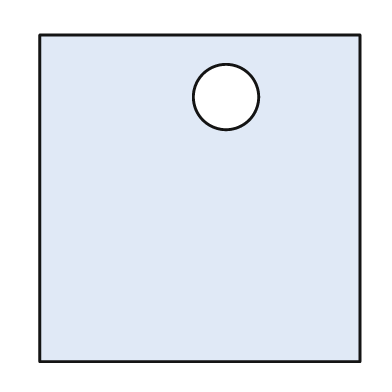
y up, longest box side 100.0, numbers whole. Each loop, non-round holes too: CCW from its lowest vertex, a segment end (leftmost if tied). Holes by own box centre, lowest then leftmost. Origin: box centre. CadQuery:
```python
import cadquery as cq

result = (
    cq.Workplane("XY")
    .moveTo(-49.0, -50.0)
    .lineTo(49.0, -50.0)
    .lineTo(49.0, 50.0)
    .lineTo(-49.0, 50.0)
    .close()
    .moveTo(8.0, 31.0)
    .circle(10.0)
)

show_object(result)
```